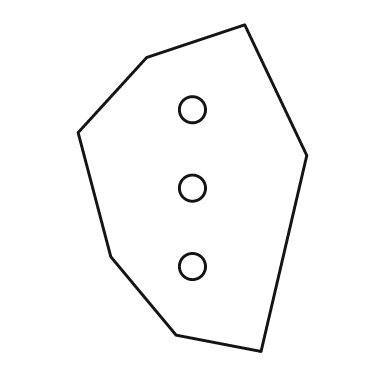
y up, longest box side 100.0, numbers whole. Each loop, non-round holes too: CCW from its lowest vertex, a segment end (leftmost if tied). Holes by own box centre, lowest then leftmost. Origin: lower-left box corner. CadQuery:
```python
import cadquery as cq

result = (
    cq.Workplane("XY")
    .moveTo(56.0, 0.0)
    .lineTo(70.0, 60.0)
    .lineTo(51.0, 100.0)
    .lineTo(21.0, 90.0)
    .lineTo(0.0, 67.0)
    .lineTo(10.0, 29.0)
    .lineTo(30.0, 5.0)
    .close()
    .moveTo(35.0, 26.0)
    .circle(4.0)
    .moveTo(35.0, 50.0)
    .circle(4.0)
    .moveTo(35.0, 74.0)
    .circle(4.0)
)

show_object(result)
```